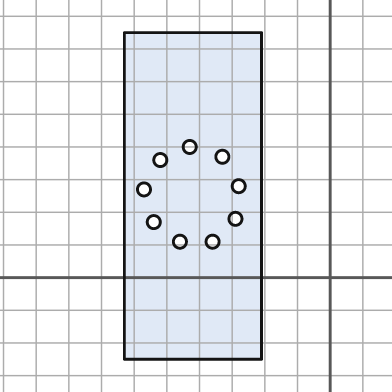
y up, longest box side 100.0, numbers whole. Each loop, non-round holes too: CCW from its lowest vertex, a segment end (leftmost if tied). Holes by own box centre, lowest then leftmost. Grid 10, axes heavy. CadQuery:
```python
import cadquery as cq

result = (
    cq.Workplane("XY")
    .moveTo(-63.0, -25.0)
    .lineTo(-21.0, -25.0)
    .lineTo(-21.0, 75.0)
    .lineTo(-63.0, 75.0)
    .close()
    .moveTo(-46.0, 11.0)
    .circle(2.0)
    .moveTo(-36.0, 11.0)
    .circle(2.0)
    .moveTo(-54.0, 17.0)
    .circle(2.0)
    .moveTo(-29.0, 18.0)
    .circle(2.0)
    .moveTo(-57.0, 27.0)
    .circle(2.0)
    .moveTo(-28.0, 28.0)
    .circle(2.0)
    .moveTo(-52.0, 36.0)
    .circle(2.0)
    .moveTo(-33.0, 37.0)
    .circle(2.0)
    .moveTo(-43.0, 40.0)
    .circle(2.0)
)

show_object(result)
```